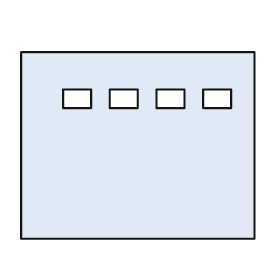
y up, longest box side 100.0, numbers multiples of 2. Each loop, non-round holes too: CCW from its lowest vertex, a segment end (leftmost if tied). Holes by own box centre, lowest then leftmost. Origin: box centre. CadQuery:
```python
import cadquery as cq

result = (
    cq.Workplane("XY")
    .moveTo(-50.0, -40.0)
    .lineTo(50.0, -40.0)
    .lineTo(50.0, 40.0)
    .lineTo(-50.0, 40.0)
    .close()
    .moveTo(-32.0, 16.0)
    .lineTo(-20.0, 16.0)
    .lineTo(-20.0, 24.0)
    .lineTo(-32.0, 24.0)
    .close()
    .moveTo(-12.0, 16.0)
    .lineTo(0.0, 16.0)
    .lineTo(0.0, 24.0)
    .lineTo(-12.0, 24.0)
    .close()
    .moveTo(8.0, 16.0)
    .lineTo(20.0, 16.0)
    .lineTo(20.0, 24.0)
    .lineTo(8.0, 24.0)
    .close()
    .moveTo(28.0, 16.0)
    .lineTo(40.0, 16.0)
    .lineTo(40.0, 24.0)
    .lineTo(28.0, 24.0)
    .close()
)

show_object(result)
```